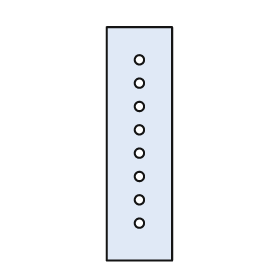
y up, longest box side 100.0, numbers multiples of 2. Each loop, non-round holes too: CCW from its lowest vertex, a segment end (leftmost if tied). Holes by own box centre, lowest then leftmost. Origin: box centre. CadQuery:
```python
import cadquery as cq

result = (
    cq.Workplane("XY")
    .moveTo(-14.0, -50.0)
    .lineTo(14.0, -50.0)
    .lineTo(14.0, 50.0)
    .lineTo(-14.0, 50.0)
    .close()
    .moveTo(0.0, -34.0)
    .circle(2.0)
    .moveTo(0.0, -24.0)
    .circle(2.0)
    .moveTo(0.0, -14.0)
    .circle(2.0)
    .moveTo(0.0, -4.0)
    .circle(2.0)
    .moveTo(0.0, 6.0)
    .circle(2.0)
    .moveTo(0.0, 16.0)
    .circle(2.0)
    .moveTo(0.0, 26.0)
    .circle(2.0)
    .moveTo(0.0, 36.0)
    .circle(2.0)
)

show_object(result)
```